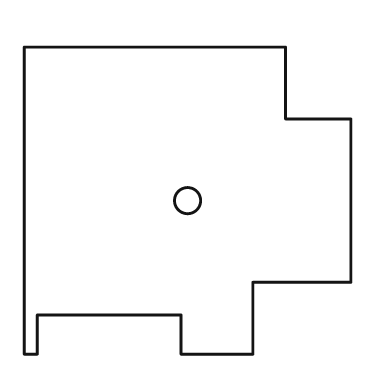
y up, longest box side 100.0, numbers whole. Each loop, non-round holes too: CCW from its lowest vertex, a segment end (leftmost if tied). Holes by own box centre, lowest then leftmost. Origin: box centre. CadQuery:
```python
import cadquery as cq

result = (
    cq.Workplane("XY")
    .moveTo(-50.0, -47.0)
    .lineTo(-46.0, -47.0)
    .lineTo(-46.0, -35.0)
    .lineTo(-2.0, -35.0)
    .lineTo(-2.0, -47.0)
    .lineTo(20.0, -47.0)
    .lineTo(20.0, -25.0)
    .lineTo(50.0, -25.0)
    .lineTo(50.0, 25.0)
    .lineTo(30.0, 25.0)
    .lineTo(30.0, 47.0)
    .lineTo(-50.0, 47.0)
    .close()
    .moveTo(0.0, 0.0)
    .circle(4.0)
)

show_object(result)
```